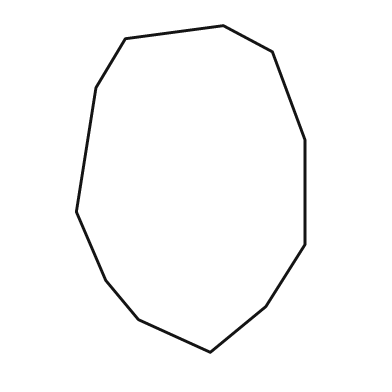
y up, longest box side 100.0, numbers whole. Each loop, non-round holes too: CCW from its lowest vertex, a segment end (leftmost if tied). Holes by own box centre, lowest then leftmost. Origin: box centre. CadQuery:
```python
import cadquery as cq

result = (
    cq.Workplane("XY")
    .moveTo(6.0, -50.0)
    .lineTo(23.0, -36.0)
    .lineTo(35.0, -17.0)
    .lineTo(35.0, 15.0)
    .lineTo(25.0, 42.0)
    .lineTo(10.0, 50.0)
    .lineTo(-20.0, 46.0)
    .lineTo(-29.0, 31.0)
    .lineTo(-35.0, -7.0)
    .lineTo(-26.0, -28.0)
    .lineTo(-16.0, -40.0)
    .close()
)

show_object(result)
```